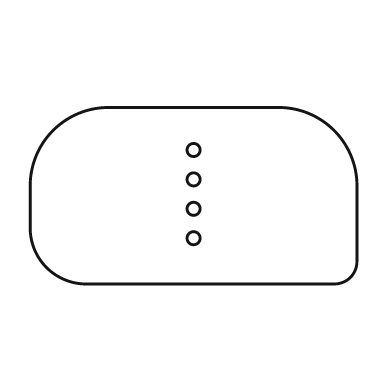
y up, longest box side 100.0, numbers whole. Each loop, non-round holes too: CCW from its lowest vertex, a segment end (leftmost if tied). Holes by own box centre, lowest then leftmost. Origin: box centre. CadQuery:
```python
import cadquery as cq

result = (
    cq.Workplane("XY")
    .moveTo(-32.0, -27.0)
    .lineTo(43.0, -27.0)
    .threePointArc((48.0, -25.0), (50.0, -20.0))
    .lineTo(50.0, 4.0)
    .threePointArc((43.0, 20.0), (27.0, 27.0))
    .lineTo(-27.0, 27.0)
    .threePointArc((-43.0, 20.0), (-50.0, 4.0))
    .lineTo(-50.0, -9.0)
    .threePointArc((-45.0, -22.0), (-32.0, -27.0))
    .close()
    .moveTo(0.0, -13.0)
    .circle(2.0)
    .moveTo(0.0, -4.0)
    .circle(2.0)
    .moveTo(0.0, 5.0)
    .circle(2.0)
    .moveTo(0.0, 14.0)
    .circle(2.0)
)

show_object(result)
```